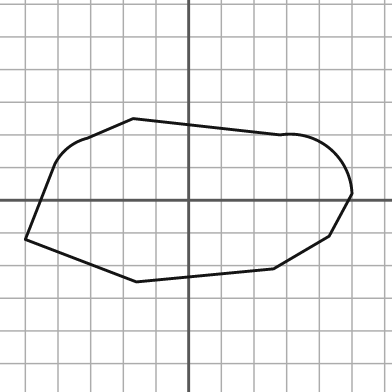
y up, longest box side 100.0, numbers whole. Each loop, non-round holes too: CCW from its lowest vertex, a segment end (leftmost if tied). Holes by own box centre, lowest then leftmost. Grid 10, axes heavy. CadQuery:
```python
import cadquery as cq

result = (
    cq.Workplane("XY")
    .moveTo(-16.0, -25.0)
    .lineTo(26.0, -21.0)
    .lineTo(43.0, -11.0)
    .lineTo(50.0, 2.0)
    .threePointArc((43.0, 16.0), (28.0, 20.0))
    .lineTo(-17.0, 25.0)
    .lineTo(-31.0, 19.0)
    .threePointArc((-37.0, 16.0), (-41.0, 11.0))
    .lineTo(-50.0, -12.0)
    .close()
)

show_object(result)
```